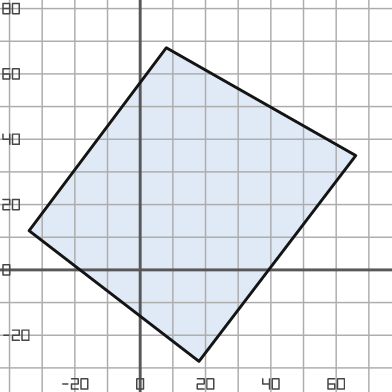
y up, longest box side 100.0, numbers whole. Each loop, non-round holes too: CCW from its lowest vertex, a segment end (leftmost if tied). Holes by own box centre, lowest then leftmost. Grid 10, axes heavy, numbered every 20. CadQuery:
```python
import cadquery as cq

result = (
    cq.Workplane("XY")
    .moveTo(18.0, -28.0)
    .lineTo(66.0, 35.0)
    .lineTo(8.0, 68.0)
    .lineTo(-34.0, 12.0)
    .close()
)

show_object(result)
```